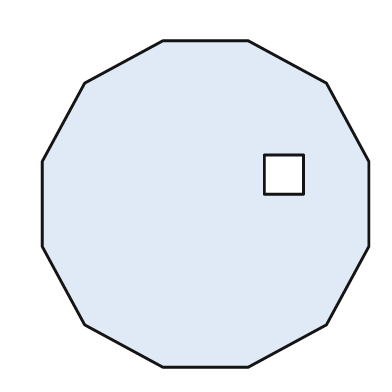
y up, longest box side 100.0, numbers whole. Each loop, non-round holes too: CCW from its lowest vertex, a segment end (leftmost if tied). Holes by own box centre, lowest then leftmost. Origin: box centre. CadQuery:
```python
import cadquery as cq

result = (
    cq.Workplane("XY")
    .moveTo(-13.0, -50.0)
    .lineTo(13.0, -50.0)
    .lineTo(37.0, -37.0)
    .lineTo(50.0, -13.0)
    .lineTo(50.0, 13.0)
    .lineTo(37.0, 37.0)
    .lineTo(13.0, 50.0)
    .lineTo(-13.0, 50.0)
    .lineTo(-37.0, 37.0)
    .lineTo(-50.0, 13.0)
    .lineTo(-50.0, -13.0)
    .lineTo(-37.0, -37.0)
    .close()
    .moveTo(18.0, 3.0)
    .lineTo(30.0, 3.0)
    .lineTo(30.0, 15.0)
    .lineTo(18.0, 15.0)
    .close()
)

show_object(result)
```